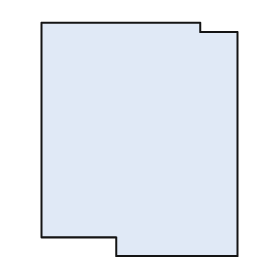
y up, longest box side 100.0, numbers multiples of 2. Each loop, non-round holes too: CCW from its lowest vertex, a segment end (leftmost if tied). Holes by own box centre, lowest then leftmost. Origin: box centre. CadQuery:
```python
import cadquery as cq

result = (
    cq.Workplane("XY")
    .moveTo(-10.0, -50.0)
    .lineTo(42.0, -50.0)
    .lineTo(42.0, 46.0)
    .lineTo(26.0, 46.0)
    .lineTo(26.0, 50.0)
    .lineTo(-42.0, 50.0)
    .lineTo(-42.0, -42.0)
    .lineTo(-10.0, -42.0)
    .close()
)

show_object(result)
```